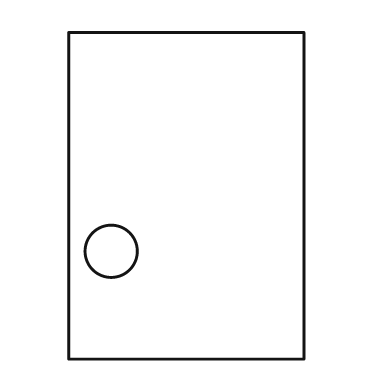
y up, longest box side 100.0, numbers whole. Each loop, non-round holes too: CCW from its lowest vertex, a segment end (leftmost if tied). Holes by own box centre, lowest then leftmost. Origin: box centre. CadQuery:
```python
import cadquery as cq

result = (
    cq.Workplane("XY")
    .moveTo(-36.0, -50.0)
    .lineTo(36.0, -50.0)
    .lineTo(36.0, 50.0)
    .lineTo(-36.0, 50.0)
    .close()
    .moveTo(-23.0, -17.0)
    .circle(8.0)
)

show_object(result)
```